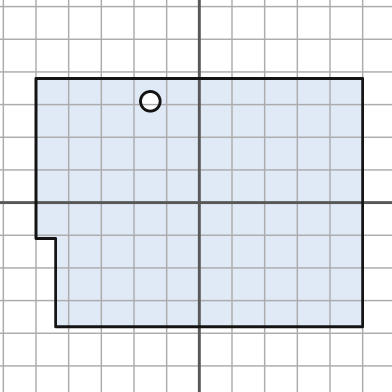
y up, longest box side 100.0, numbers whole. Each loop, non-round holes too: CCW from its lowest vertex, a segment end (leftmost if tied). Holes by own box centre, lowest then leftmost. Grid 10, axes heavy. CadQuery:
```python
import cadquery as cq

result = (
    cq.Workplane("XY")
    .moveTo(-44.0, -38.0)
    .lineTo(50.0, -38.0)
    .lineTo(50.0, 38.0)
    .lineTo(-50.0, 38.0)
    .lineTo(-50.0, -11.0)
    .lineTo(-44.0, -11.0)
    .close()
    .moveTo(-15.0, 31.0)
    .circle(3.0)
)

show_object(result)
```